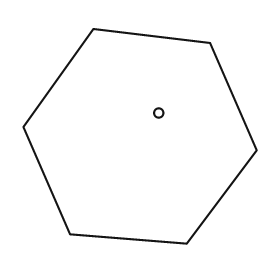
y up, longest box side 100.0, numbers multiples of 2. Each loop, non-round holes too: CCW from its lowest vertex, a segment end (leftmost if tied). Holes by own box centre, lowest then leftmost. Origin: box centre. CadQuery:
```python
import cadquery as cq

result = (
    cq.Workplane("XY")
    .moveTo(20.0, -46.0)
    .lineTo(50.0, -6.0)
    .lineTo(30.0, 40.0)
    .lineTo(-20.0, 46.0)
    .lineTo(-50.0, 4.0)
    .lineTo(-30.0, -42.0)
    .close()
    .moveTo(8.0, 10.0)
    .circle(2.0)
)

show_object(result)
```